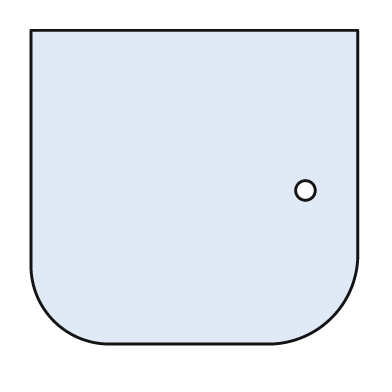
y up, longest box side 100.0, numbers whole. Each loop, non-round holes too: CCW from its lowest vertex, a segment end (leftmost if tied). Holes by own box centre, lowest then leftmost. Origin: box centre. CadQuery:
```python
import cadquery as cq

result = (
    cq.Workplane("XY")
    .moveTo(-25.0, -48.0)
    .lineTo(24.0, -48.0)
    .threePointArc((42.0, -40.0), (50.0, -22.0))
    .lineTo(50.0, 48.0)
    .lineTo(-50.0, 48.0)
    .lineTo(-50.0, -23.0)
    .threePointArc((-43.0, -41.0), (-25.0, -48.0))
    .close()
    .moveTo(34.0, -1.0)
    .circle(3.0)
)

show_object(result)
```